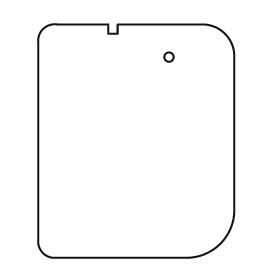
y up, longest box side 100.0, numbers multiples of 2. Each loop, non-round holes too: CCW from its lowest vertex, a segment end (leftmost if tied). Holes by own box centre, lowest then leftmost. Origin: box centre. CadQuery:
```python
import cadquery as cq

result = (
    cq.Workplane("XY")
    .moveTo(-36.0, -50.0)
    .lineTo(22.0, -50.0)
    .threePointArc((36.0, -44.0), (42.0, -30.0))
    .lineTo(42.0, 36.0)
    .threePointArc((38.0, 46.0), (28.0, 50.0))
    .lineTo(-8.0, 50.0)
    .lineTo(-8.0, 46.0)
    .lineTo(-12.0, 46.0)
    .lineTo(-12.0, 50.0)
    .lineTo(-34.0, 50.0)
    .threePointArc((-40.0, 48.0), (-42.0, 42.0))
    .lineTo(-42.0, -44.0)
    .threePointArc((-40.0, -48.0), (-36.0, -50.0))
    .close()
    .moveTo(14.0, 36.0)
    .circle(2.0)
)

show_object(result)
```